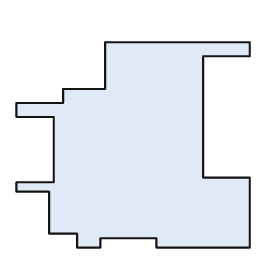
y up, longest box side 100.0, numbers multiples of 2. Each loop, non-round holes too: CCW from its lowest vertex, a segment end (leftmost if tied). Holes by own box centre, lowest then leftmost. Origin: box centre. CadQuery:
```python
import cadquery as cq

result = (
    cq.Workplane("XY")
    .moveTo(-24.0, -44.0)
    .lineTo(-14.0, -44.0)
    .lineTo(-14.0, -40.0)
    .lineTo(10.0, -40.0)
    .lineTo(10.0, -44.0)
    .lineTo(50.0, -44.0)
    .lineTo(50.0, -14.0)
    .lineTo(30.0, -14.0)
    .lineTo(30.0, 38.0)
    .lineTo(50.0, 38.0)
    .lineTo(50.0, 44.0)
    .lineTo(-12.0, 44.0)
    .lineTo(-12.0, 24.0)
    .lineTo(-30.0, 24.0)
    .lineTo(-30.0, 18.0)
    .lineTo(-50.0, 18.0)
    .lineTo(-50.0, 12.0)
    .lineTo(-34.0, 12.0)
    .lineTo(-34.0, -16.0)
    .lineTo(-50.0, -16.0)
    .lineTo(-50.0, -20.0)
    .lineTo(-36.0, -20.0)
    .lineTo(-36.0, -38.0)
    .lineTo(-24.0, -38.0)
    .close()
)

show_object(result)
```